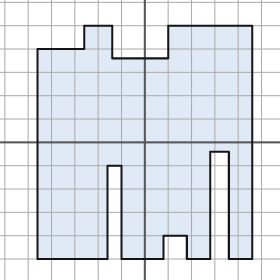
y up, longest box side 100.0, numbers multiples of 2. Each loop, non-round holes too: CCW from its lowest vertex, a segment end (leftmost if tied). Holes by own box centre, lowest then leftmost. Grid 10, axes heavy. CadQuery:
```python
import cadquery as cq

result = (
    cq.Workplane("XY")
    .moveTo(-46.0, -50.0)
    .lineTo(-16.0, -50.0)
    .lineTo(-16.0, -10.0)
    .lineTo(-10.0, -10.0)
    .lineTo(-10.0, -50.0)
    .lineTo(8.0, -50.0)
    .lineTo(8.0, -40.0)
    .lineTo(18.0, -40.0)
    .lineTo(18.0, -50.0)
    .lineTo(28.0, -50.0)
    .lineTo(28.0, -4.0)
    .lineTo(36.0, -4.0)
    .lineTo(36.0, -50.0)
    .lineTo(46.0, -50.0)
    .lineTo(46.0, 50.0)
    .lineTo(10.0, 50.0)
    .lineTo(10.0, 36.0)
    .lineTo(-14.0, 36.0)
    .lineTo(-14.0, 50.0)
    .lineTo(-26.0, 50.0)
    .lineTo(-26.0, 40.0)
    .lineTo(-46.0, 40.0)
    .close()
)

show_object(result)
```